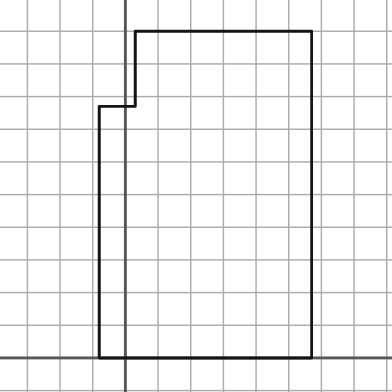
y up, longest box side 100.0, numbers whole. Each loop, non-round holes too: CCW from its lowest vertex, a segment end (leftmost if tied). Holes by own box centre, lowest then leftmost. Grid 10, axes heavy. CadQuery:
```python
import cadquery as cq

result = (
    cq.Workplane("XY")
    .moveTo(-8.0, 0.0)
    .lineTo(57.0, 0.0)
    .lineTo(57.0, 100.0)
    .lineTo(3.0, 100.0)
    .lineTo(3.0, 77.0)
    .lineTo(-8.0, 77.0)
    .close()
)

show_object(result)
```